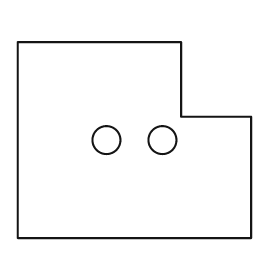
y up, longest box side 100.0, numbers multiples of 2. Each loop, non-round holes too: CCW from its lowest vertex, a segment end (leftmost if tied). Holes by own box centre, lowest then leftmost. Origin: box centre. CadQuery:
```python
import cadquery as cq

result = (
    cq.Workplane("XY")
    .moveTo(-50.0, -42.0)
    .lineTo(50.0, -42.0)
    .lineTo(50.0, 10.0)
    .lineTo(20.0, 10.0)
    .lineTo(20.0, 42.0)
    .lineTo(-50.0, 42.0)
    .close()
    .moveTo(-12.0, 0.0)
    .circle(6.0)
    .moveTo(12.0, 0.0)
    .circle(6.0)
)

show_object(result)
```